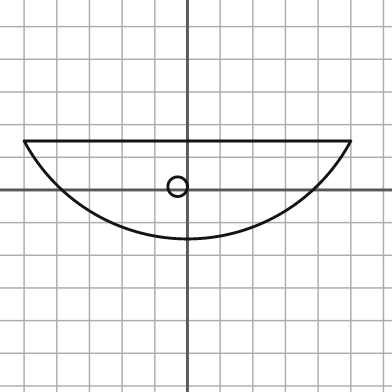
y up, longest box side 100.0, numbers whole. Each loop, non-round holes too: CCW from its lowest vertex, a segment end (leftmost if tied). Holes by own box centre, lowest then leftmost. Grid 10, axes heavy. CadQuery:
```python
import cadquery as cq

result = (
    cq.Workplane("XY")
    .moveTo(-50.0, 15.0)
    .threePointArc((0.0, -15.0), (50.0, 15.0))
    .close()
    .moveTo(-3.0, 1.0)
    .circle(3.0)
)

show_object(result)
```